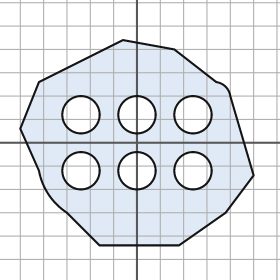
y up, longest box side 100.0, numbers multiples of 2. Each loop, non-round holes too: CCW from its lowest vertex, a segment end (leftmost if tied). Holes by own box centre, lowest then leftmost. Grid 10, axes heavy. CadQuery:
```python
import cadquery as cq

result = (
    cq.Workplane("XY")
    .moveTo(-16.0, -44.0)
    .lineTo(18.0, -44.0)
    .lineTo(38.0, -30.0)
    .lineTo(50.0, -14.0)
    .lineTo(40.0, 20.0)
    .threePointArc((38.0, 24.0), (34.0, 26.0))
    .lineTo(16.0, 40.0)
    .lineTo(-6.0, 44.0)
    .lineTo(-42.0, 26.0)
    .lineTo(-50.0, 6.0)
    .lineTo(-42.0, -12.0)
    .threePointArc((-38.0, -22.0), (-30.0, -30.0))
    .close()
    .moveTo(-24.0, -12.0)
    .circle(8.0)
    .moveTo(0.0, -12.0)
    .circle(8.0)
    .moveTo(24.0, -12.0)
    .circle(8.0)
    .moveTo(-24.0, 12.0)
    .circle(8.0)
    .moveTo(0.0, 12.0)
    .circle(8.0)
    .moveTo(24.0, 12.0)
    .circle(8.0)
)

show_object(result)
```